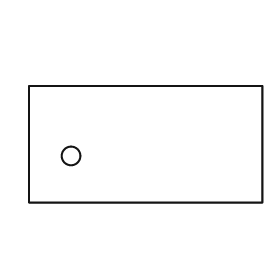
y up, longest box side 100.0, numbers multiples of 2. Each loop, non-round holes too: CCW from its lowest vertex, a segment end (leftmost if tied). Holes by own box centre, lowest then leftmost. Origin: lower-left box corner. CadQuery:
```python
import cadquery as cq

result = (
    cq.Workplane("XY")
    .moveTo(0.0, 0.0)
    .lineTo(100.0, 0.0)
    .lineTo(100.0, 50.0)
    .lineTo(0.0, 50.0)
    .close()
    .moveTo(18.0, 20.0)
    .circle(4.0)
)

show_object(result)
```